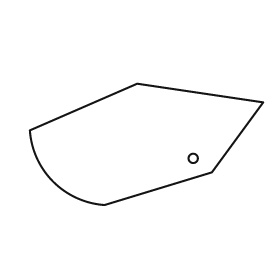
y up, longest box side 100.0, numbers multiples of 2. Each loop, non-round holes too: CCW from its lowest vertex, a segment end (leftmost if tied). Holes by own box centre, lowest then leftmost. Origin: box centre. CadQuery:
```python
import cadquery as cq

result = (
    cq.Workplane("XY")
    .moveTo(-18.0, -26.0)
    .lineTo(28.0, -12.0)
    .lineTo(50.0, 18.0)
    .lineTo(-4.0, 26.0)
    .lineTo(-50.0, 6.0)
    .threePointArc((-40.0, -16.0), (-18.0, -26.0))
    .close()
    .moveTo(20.0, -6.0)
    .circle(2.0)
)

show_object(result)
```